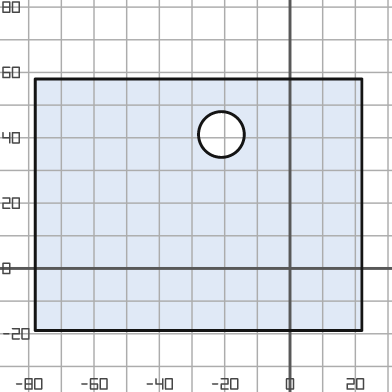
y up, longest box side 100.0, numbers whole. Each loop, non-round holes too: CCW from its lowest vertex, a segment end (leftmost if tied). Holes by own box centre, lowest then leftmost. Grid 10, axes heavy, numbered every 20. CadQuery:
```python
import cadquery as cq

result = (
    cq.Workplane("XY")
    .moveTo(-78.0, -19.0)
    .lineTo(22.0, -19.0)
    .lineTo(22.0, 58.0)
    .lineTo(-78.0, 58.0)
    .close()
    .moveTo(-21.0, 41.0)
    .circle(7.0)
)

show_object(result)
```